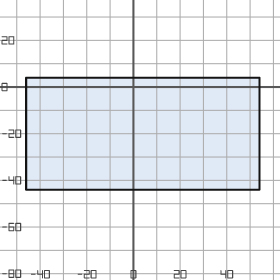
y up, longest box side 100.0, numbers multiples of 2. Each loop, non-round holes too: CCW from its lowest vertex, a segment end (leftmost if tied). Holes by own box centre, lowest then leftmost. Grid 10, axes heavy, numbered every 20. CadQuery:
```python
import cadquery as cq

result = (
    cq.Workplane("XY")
    .moveTo(-46.0, -44.0)
    .lineTo(54.0, -44.0)
    .lineTo(54.0, 4.0)
    .lineTo(-46.0, 4.0)
    .close()
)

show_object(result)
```